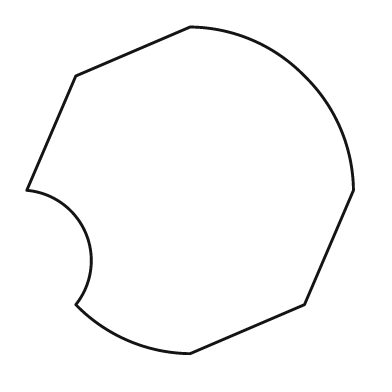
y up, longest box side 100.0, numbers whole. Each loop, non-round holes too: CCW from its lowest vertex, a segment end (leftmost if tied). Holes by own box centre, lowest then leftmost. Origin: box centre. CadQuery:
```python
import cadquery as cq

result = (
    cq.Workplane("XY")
    .moveTo(0.0, -50.0)
    .lineTo(35.0, -35.0)
    .lineTo(50.0, 0.0)
    .threePointArc((46.0, 19.0), (35.0, 35.0))
    .threePointArc((19.0, 46.0), (0.0, 50.0))
    .lineTo(-35.0, 35.0)
    .lineTo(-50.0, 0.0)
    .threePointArc((-32.0, -13.0), (-35.0, -35.0))
    .threePointArc((-19.0, -46.0), (0.0, -50.0))
    .close()
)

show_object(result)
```